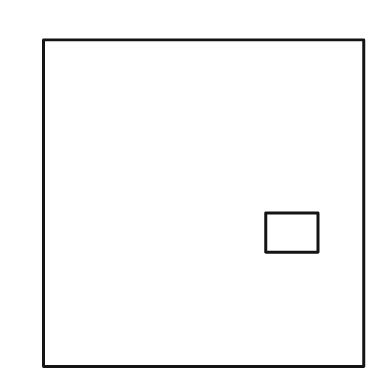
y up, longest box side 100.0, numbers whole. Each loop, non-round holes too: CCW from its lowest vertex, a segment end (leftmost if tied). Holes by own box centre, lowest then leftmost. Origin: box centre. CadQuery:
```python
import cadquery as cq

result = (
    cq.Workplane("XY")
    .moveTo(-49.0, -50.0)
    .lineTo(49.0, -50.0)
    .lineTo(49.0, 50.0)
    .lineTo(-49.0, 50.0)
    .close()
    .moveTo(19.0, -15.0)
    .lineTo(35.0, -15.0)
    .lineTo(35.0, -3.0)
    .lineTo(19.0, -3.0)
    .close()
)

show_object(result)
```